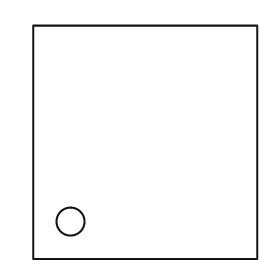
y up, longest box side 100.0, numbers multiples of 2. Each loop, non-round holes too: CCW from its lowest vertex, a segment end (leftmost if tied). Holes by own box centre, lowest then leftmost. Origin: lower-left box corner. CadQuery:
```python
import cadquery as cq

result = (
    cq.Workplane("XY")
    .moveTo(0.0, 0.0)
    .lineTo(96.0, 0.0)
    .lineTo(96.0, 100.0)
    .lineTo(0.0, 100.0)
    .close()
    .moveTo(16.0, 16.0)
    .circle(6.0)
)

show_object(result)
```